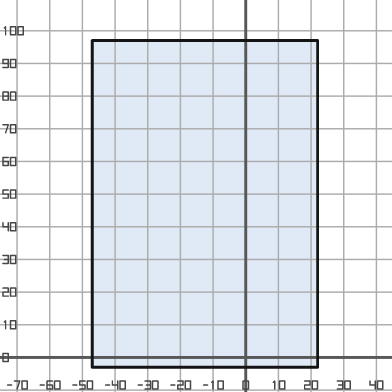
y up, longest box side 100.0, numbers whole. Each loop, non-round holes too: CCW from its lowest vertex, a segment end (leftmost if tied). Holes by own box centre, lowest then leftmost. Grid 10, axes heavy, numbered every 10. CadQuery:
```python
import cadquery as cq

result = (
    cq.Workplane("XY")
    .moveTo(-47.0, -3.0)
    .lineTo(22.0, -3.0)
    .lineTo(22.0, 97.0)
    .lineTo(-47.0, 97.0)
    .close()
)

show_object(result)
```